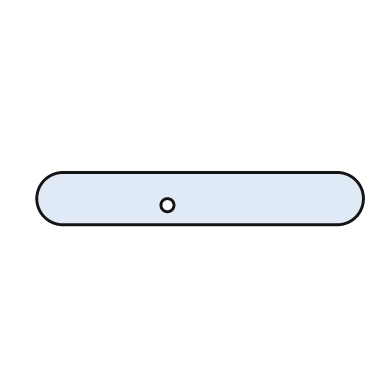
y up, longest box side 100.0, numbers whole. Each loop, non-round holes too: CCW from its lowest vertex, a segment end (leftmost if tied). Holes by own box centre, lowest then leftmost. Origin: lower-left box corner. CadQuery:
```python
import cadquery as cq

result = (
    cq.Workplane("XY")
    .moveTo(8.0, 0.0)
    .lineTo(92.0, 0.0)
    .threePointArc((100.0, 8.0), (92.0, 16.0))
    .lineTo(8.0, 16.0)
    .threePointArc((0.0, 8.0), (8.0, 0.0))
    .close()
    .moveTo(40.0, 6.0)
    .circle(2.0)
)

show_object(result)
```